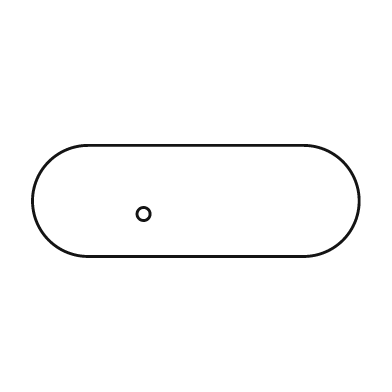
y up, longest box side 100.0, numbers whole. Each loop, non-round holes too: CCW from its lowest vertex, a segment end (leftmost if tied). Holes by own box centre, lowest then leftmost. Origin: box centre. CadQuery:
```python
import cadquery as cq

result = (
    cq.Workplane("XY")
    .moveTo(-33.0, -17.0)
    .lineTo(33.0, -17.0)
    .threePointArc((50.0, 0.0), (33.0, 17.0))
    .lineTo(-33.0, 17.0)
    .threePointArc((-50.0, 0.0), (-33.0, -17.0))
    .close()
    .moveTo(-16.0, -4.0)
    .circle(2.0)
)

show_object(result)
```